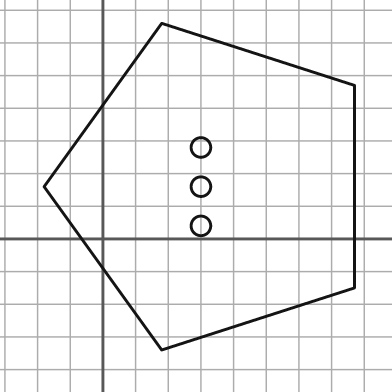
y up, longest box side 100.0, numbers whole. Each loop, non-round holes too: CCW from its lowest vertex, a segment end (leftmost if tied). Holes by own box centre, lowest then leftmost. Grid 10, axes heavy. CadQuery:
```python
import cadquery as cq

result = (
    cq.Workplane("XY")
    .moveTo(18.0, -34.0)
    .lineTo(77.0, -15.0)
    .lineTo(77.0, 47.0)
    .lineTo(18.0, 66.0)
    .lineTo(-18.0, 16.0)
    .close()
    .moveTo(30.0, 4.0)
    .circle(3.0)
    .moveTo(30.0, 16.0)
    .circle(3.0)
    .moveTo(30.0, 28.0)
    .circle(3.0)
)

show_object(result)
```